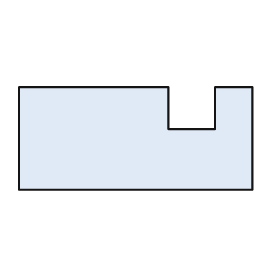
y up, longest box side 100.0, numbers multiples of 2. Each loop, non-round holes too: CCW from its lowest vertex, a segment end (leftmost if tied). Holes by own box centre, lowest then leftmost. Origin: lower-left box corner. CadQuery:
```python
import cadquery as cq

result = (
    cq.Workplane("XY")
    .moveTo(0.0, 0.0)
    .lineTo(100.0, 0.0)
    .lineTo(100.0, 44.0)
    .lineTo(84.0, 44.0)
    .lineTo(84.0, 26.0)
    .lineTo(64.0, 26.0)
    .lineTo(64.0, 44.0)
    .lineTo(0.0, 44.0)
    .close()
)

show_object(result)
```